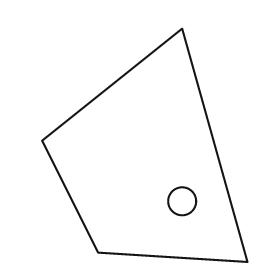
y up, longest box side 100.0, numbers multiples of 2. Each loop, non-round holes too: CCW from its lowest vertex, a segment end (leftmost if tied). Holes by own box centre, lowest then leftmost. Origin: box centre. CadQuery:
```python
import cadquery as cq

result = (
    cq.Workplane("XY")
    .moveTo(44.0, -50.0)
    .lineTo(16.0, 50.0)
    .lineTo(-44.0, 2.0)
    .lineTo(-20.0, -46.0)
    .close()
    .moveTo(16.0, -24.0)
    .circle(6.0)
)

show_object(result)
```